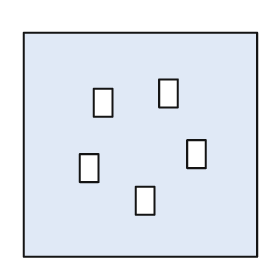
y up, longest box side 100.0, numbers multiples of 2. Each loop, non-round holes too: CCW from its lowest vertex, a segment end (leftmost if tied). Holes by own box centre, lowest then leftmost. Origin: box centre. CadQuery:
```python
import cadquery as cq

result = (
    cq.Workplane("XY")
    .moveTo(-50.0, -48.0)
    .lineTo(50.0, -48.0)
    .lineTo(50.0, 48.0)
    .lineTo(-50.0, 48.0)
    .close()
    .moveTo(-2.0, -30.0)
    .lineTo(6.0, -30.0)
    .lineTo(6.0, -18.0)
    .lineTo(-2.0, -18.0)
    .close()
    .moveTo(-26.0, -16.0)
    .lineTo(-18.0, -16.0)
    .lineTo(-18.0, -4.0)
    .lineTo(-26.0, -4.0)
    .close()
    .moveTo(20.0, -10.0)
    .lineTo(28.0, -10.0)
    .lineTo(28.0, 2.0)
    .lineTo(20.0, 2.0)
    .close()
    .moveTo(-20.0, 12.0)
    .lineTo(-12.0, 12.0)
    .lineTo(-12.0, 24.0)
    .lineTo(-20.0, 24.0)
    .close()
    .moveTo(8.0, 16.0)
    .lineTo(16.0, 16.0)
    .lineTo(16.0, 28.0)
    .lineTo(8.0, 28.0)
    .close()
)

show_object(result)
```